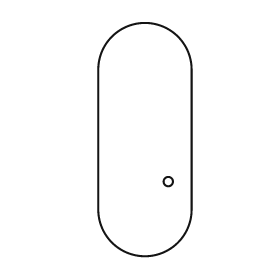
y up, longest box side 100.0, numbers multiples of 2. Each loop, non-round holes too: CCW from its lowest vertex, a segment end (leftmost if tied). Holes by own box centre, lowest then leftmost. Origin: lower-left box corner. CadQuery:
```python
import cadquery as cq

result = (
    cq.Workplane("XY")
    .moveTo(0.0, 20.0)
    .threePointArc((20.0, 0.0), (40.0, 20.0))
    .lineTo(40.0, 80.0)
    .threePointArc((20.0, 100.0), (0.0, 80.0))
    .close()
    .moveTo(30.0, 32.0)
    .circle(2.0)
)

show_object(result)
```